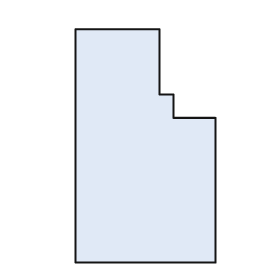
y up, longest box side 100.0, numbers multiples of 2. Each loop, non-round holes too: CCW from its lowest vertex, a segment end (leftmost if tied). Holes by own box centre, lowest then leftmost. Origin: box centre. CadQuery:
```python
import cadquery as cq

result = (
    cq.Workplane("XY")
    .moveTo(-30.0, -50.0)
    .lineTo(30.0, -50.0)
    .lineTo(30.0, 12.0)
    .lineTo(12.0, 12.0)
    .lineTo(12.0, 22.0)
    .lineTo(6.0, 22.0)
    .lineTo(6.0, 50.0)
    .lineTo(-30.0, 50.0)
    .close()
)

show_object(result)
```